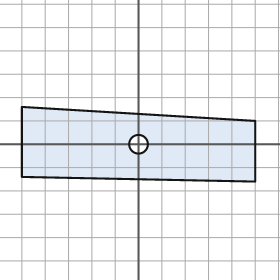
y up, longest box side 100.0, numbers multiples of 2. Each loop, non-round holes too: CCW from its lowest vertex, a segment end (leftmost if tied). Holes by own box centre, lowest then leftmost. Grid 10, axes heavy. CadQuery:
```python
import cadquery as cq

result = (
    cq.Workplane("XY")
    .moveTo(50.0, -16.0)
    .lineTo(50.0, 10.0)
    .lineTo(-50.0, 16.0)
    .lineTo(-50.0, -14.0)
    .close()
    .moveTo(0.0, 0.0)
    .circle(4.0)
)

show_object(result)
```